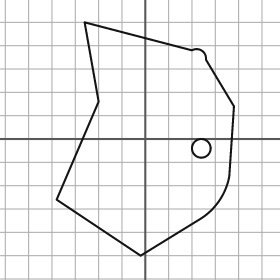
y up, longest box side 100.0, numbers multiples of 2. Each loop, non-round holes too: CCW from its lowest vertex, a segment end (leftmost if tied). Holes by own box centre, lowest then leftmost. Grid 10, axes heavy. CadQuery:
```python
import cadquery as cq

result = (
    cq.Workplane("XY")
    .moveTo(-2.0, -50.0)
    .lineTo(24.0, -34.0)
    .threePointArc((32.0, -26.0), (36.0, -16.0))
    .lineTo(38.0, 14.0)
    .lineTo(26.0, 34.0)
    .threePointArc((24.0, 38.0), (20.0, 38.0))
    .lineTo(-26.0, 50.0)
    .lineTo(-20.0, 16.0)
    .lineTo(-38.0, -26.0)
    .close()
    .moveTo(24.0, -4.0)
    .circle(4.0)
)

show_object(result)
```